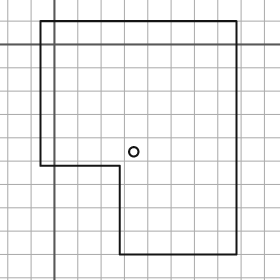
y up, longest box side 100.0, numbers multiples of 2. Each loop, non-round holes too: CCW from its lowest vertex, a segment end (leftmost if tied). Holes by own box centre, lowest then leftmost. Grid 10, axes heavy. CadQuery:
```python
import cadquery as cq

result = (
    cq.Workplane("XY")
    .moveTo(28.0, -90.0)
    .lineTo(78.0, -90.0)
    .lineTo(78.0, 10.0)
    .lineTo(-6.0, 10.0)
    .lineTo(-6.0, -52.0)
    .lineTo(28.0, -52.0)
    .close()
    .moveTo(34.0, -46.0)
    .circle(2.0)
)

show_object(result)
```